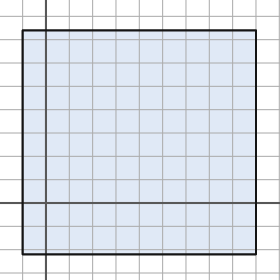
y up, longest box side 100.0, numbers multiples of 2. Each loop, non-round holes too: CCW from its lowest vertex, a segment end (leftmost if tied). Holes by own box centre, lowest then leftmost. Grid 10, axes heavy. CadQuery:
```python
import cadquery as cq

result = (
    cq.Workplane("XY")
    .moveTo(-10.0, -22.0)
    .lineTo(90.0, -22.0)
    .lineTo(90.0, 74.0)
    .lineTo(-10.0, 74.0)
    .close()
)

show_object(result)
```